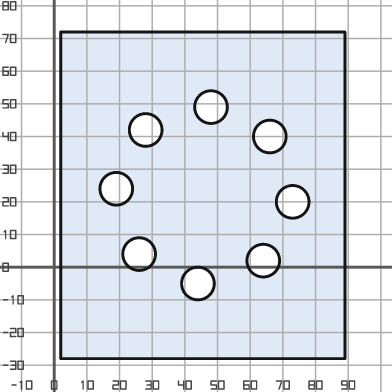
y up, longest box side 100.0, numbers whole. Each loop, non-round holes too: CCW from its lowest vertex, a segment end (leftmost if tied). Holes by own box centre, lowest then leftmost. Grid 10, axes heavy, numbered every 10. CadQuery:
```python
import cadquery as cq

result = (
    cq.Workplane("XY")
    .moveTo(2.0, -28.0)
    .lineTo(89.0, -28.0)
    .lineTo(89.0, 72.0)
    .lineTo(2.0, 72.0)
    .close()
    .moveTo(44.0, -5.0)
    .circle(5.0)
    .moveTo(64.0, 2.0)
    .circle(5.0)
    .moveTo(26.0, 4.0)
    .circle(5.0)
    .moveTo(73.0, 20.0)
    .circle(5.0)
    .moveTo(19.0, 24.0)
    .circle(5.0)
    .moveTo(66.0, 40.0)
    .circle(5.0)
    .moveTo(28.0, 42.0)
    .circle(5.0)
    .moveTo(48.0, 49.0)
    .circle(5.0)
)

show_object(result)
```